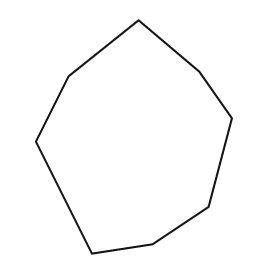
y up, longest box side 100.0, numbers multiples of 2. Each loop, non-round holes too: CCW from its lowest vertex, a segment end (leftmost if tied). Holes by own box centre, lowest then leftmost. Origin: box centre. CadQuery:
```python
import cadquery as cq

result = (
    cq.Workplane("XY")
    .moveTo(-18.0, -50.0)
    .lineTo(8.0, -46.0)
    .lineTo(32.0, -30.0)
    .lineTo(42.0, 8.0)
    .lineTo(28.0, 28.0)
    .lineTo(2.0, 50.0)
    .lineTo(-28.0, 26.0)
    .lineTo(-42.0, -2.0)
    .close()
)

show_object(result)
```